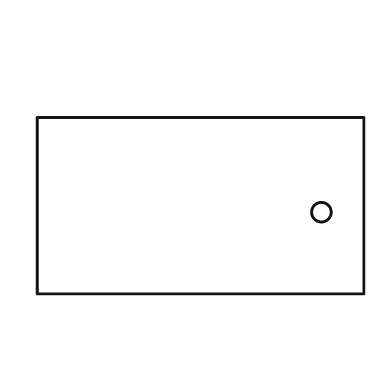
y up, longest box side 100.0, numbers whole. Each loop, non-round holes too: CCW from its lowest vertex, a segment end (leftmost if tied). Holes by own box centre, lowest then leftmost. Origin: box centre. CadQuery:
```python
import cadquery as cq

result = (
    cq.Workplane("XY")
    .moveTo(-50.0, -27.0)
    .lineTo(50.0, -27.0)
    .lineTo(50.0, 27.0)
    .lineTo(-50.0, 27.0)
    .close()
    .moveTo(37.0, -2.0)
    .circle(3.0)
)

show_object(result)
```